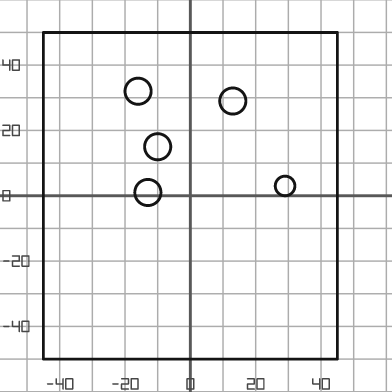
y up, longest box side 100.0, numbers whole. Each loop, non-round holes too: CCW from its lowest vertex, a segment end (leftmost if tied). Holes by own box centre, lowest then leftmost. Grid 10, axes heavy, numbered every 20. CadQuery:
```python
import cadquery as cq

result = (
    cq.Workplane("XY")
    .moveTo(-45.0, -50.0)
    .lineTo(45.0, -50.0)
    .lineTo(45.0, 50.0)
    .lineTo(-45.0, 50.0)
    .close()
    .moveTo(-13.0, 1.0)
    .circle(4.0)
    .moveTo(29.0, 3.0)
    .circle(3.0)
    .moveTo(-10.0, 15.0)
    .circle(4.0)
    .moveTo(13.0, 29.0)
    .circle(4.0)
    .moveTo(-16.0, 32.0)
    .circle(4.0)
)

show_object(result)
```